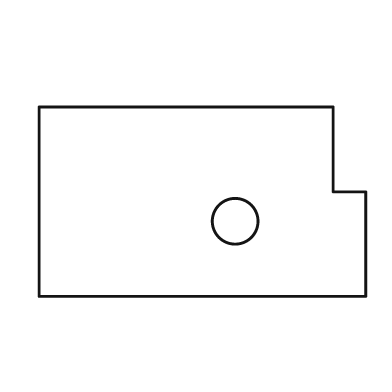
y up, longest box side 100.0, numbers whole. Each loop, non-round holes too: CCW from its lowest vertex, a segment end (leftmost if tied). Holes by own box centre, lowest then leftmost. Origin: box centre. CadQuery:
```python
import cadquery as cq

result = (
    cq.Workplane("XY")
    .moveTo(-50.0, -29.0)
    .lineTo(50.0, -29.0)
    .lineTo(50.0, 3.0)
    .lineTo(40.0, 3.0)
    .lineTo(40.0, 29.0)
    .lineTo(-50.0, 29.0)
    .close()
    .moveTo(10.0, -6.0)
    .circle(7.0)
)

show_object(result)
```